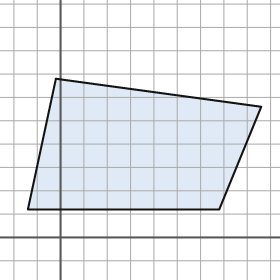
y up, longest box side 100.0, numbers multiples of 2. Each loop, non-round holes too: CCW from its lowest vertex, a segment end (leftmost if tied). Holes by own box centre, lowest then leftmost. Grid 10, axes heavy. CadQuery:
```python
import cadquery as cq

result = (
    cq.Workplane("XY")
    .moveTo(-14.0, 12.0)
    .lineTo(68.0, 12.0)
    .lineTo(86.0, 56.0)
    .lineTo(-2.0, 68.0)
    .close()
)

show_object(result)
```